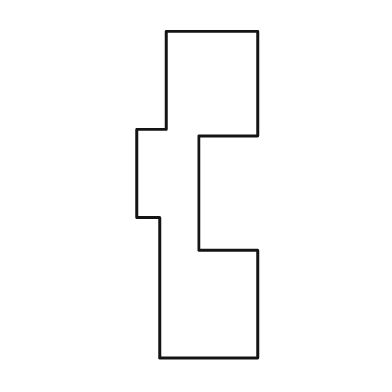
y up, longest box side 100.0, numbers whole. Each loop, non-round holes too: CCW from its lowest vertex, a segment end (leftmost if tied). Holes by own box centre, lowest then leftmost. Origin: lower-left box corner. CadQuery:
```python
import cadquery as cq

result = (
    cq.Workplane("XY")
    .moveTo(7.0, 0.0)
    .lineTo(37.0, 0.0)
    .lineTo(37.0, 33.0)
    .lineTo(19.0, 33.0)
    .lineTo(19.0, 68.0)
    .lineTo(37.0, 68.0)
    .lineTo(37.0, 100.0)
    .lineTo(9.0, 100.0)
    .lineTo(9.0, 70.0)
    .lineTo(0.0, 70.0)
    .lineTo(0.0, 43.0)
    .lineTo(7.0, 43.0)
    .close()
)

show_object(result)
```